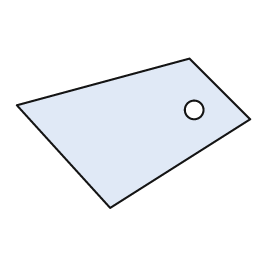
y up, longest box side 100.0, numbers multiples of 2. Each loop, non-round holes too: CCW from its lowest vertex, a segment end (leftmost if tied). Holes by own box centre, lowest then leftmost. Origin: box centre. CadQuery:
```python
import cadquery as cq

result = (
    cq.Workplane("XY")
    .moveTo(-10.0, -32.0)
    .lineTo(50.0, 6.0)
    .lineTo(24.0, 32.0)
    .lineTo(-50.0, 12.0)
    .close()
    .moveTo(26.0, 10.0)
    .circle(4.0)
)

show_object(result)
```